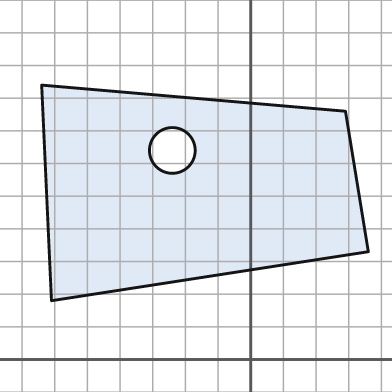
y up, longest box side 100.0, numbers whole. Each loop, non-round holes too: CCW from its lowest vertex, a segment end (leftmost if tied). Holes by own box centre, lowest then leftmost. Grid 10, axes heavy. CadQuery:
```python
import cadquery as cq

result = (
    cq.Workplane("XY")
    .moveTo(-61.0, 18.0)
    .lineTo(36.0, 33.0)
    .lineTo(29.0, 76.0)
    .lineTo(-64.0, 84.0)
    .close()
    .moveTo(-24.0, 64.0)
    .circle(7.0)
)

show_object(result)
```